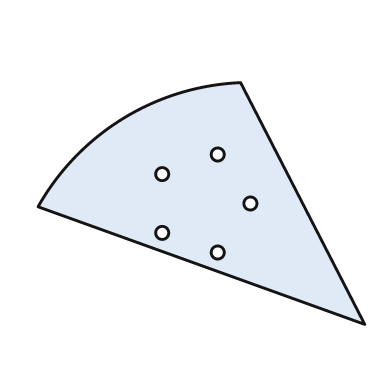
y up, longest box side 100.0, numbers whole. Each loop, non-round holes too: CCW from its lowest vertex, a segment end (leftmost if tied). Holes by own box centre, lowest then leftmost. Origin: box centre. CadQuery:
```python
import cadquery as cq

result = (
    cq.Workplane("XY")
    .moveTo(50.0, -37.0)
    .lineTo(12.0, 37.0)
    .threePointArc((-24.0, 26.0), (-50.0, -1.0))
    .close()
    .moveTo(5.0, -15.0)
    .circle(2.0)
    .moveTo(-12.0, -9.0)
    .circle(2.0)
    .moveTo(15.0, 0.0)
    .circle(2.0)
    .moveTo(-12.0, 9.0)
    .circle(2.0)
    .moveTo(5.0, 15.0)
    .circle(2.0)
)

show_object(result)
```